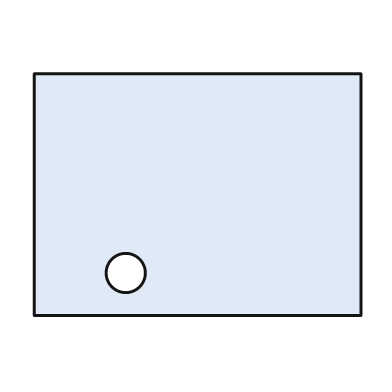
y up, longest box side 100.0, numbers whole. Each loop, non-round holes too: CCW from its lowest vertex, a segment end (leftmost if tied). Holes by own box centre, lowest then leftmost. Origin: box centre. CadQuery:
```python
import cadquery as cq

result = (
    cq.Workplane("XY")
    .moveTo(-50.0, -37.0)
    .lineTo(50.0, -37.0)
    .lineTo(50.0, 37.0)
    .lineTo(-50.0, 37.0)
    .close()
    .moveTo(-22.0, -24.0)
    .circle(6.0)
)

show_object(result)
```